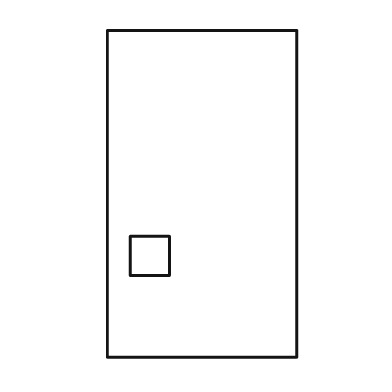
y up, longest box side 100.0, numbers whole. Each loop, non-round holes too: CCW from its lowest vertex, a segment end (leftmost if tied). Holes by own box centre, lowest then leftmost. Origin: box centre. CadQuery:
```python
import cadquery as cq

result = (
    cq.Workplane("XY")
    .moveTo(-29.0, -50.0)
    .lineTo(29.0, -50.0)
    .lineTo(29.0, 50.0)
    .lineTo(-29.0, 50.0)
    .close()
    .moveTo(-22.0, -25.0)
    .lineTo(-10.0, -25.0)
    .lineTo(-10.0, -13.0)
    .lineTo(-22.0, -13.0)
    .close()
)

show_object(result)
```